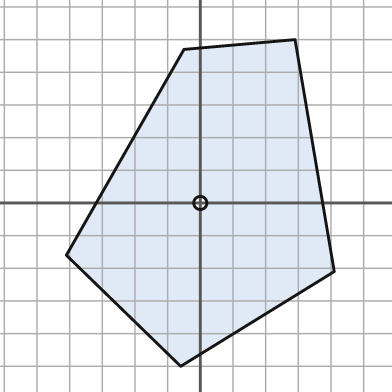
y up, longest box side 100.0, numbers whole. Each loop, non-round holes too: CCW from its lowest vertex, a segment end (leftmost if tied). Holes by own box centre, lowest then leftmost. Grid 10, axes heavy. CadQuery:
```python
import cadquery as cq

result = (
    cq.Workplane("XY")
    .moveTo(-6.0, -50.0)
    .lineTo(41.0, -21.0)
    .lineTo(29.0, 50.0)
    .lineTo(-5.0, 47.0)
    .lineTo(-41.0, -16.0)
    .close()
    .moveTo(0.0, 0.0)
    .circle(2.0)
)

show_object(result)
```